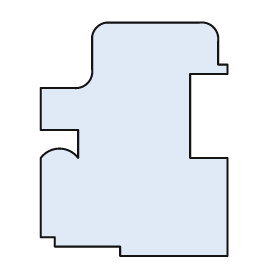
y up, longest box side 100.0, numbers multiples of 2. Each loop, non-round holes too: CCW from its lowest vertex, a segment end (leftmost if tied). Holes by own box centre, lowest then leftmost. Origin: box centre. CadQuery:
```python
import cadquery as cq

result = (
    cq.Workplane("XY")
    .moveTo(-6.0, -50.0)
    .lineTo(40.0, -50.0)
    .lineTo(40.0, -8.0)
    .lineTo(24.0, -8.0)
    .lineTo(24.0, 28.0)
    .lineTo(40.0, 28.0)
    .lineTo(40.0, 32.0)
    .lineTo(36.0, 32.0)
    .lineTo(36.0, 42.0)
    .threePointArc((34.0, 48.0), (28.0, 50.0))
    .lineTo(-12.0, 50.0)
    .threePointArc((-16.0, 48.0), (-18.0, 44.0))
    .lineTo(-18.0, 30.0)
    .threePointArc((-20.0, 24.0), (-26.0, 22.0))
    .lineTo(-40.0, 22.0)
    .lineTo(-40.0, 4.0)
    .lineTo(-24.0, 4.0)
    .lineTo(-24.0, -8.0)
    .threePointArc((-32.0, -4.0), (-40.0, -8.0))
    .lineTo(-40.0, -42.0)
    .lineTo(-34.0, -42.0)
    .lineTo(-34.0, -46.0)
    .lineTo(-6.0, -46.0)
    .close()
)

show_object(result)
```